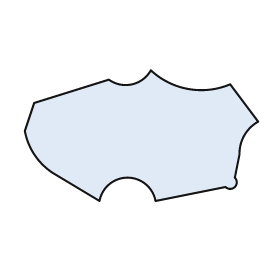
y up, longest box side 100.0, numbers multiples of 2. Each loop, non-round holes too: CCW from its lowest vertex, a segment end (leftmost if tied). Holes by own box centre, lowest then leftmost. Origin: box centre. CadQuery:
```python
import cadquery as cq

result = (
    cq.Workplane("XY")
    .moveTo(-18.0, -28.0)
    .threePointArc((-6.0, -18.0), (6.0, -28.0))
    .lineTo(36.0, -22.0)
    .threePointArc((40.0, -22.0), (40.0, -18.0))
    .lineTo(42.0, -8.0)
    .threePointArc((44.0, 0.0), (50.0, 6.0))
    .lineTo(38.0, 22.0)
    .threePointArc((20.0, 20.0), (4.0, 28.0))
    .threePointArc((-4.0, 22.0), (-14.0, 24.0))
    .lineTo(-46.0, 14.0)
    .lineTo(-50.0, 2.0)
    .threePointArc((-46.0, -8.0), (-38.0, -16.0))
    .close()
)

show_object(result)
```